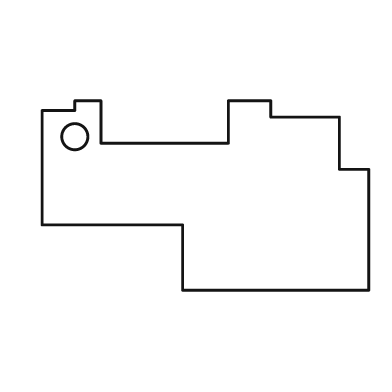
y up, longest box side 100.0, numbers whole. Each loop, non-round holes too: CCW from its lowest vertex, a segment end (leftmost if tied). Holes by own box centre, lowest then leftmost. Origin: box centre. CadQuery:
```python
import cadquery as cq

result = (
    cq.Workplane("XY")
    .moveTo(-7.0, -29.0)
    .lineTo(50.0, -29.0)
    .lineTo(50.0, 8.0)
    .lineTo(41.0, 8.0)
    .lineTo(41.0, 24.0)
    .lineTo(20.0, 24.0)
    .lineTo(20.0, 29.0)
    .lineTo(7.0, 29.0)
    .lineTo(7.0, 16.0)
    .lineTo(-32.0, 16.0)
    .lineTo(-32.0, 29.0)
    .lineTo(-40.0, 29.0)
    .lineTo(-40.0, 26.0)
    .lineTo(-50.0, 26.0)
    .lineTo(-50.0, -9.0)
    .lineTo(-7.0, -9.0)
    .close()
    .moveTo(-40.0, 18.0)
    .circle(4.0)
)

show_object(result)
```